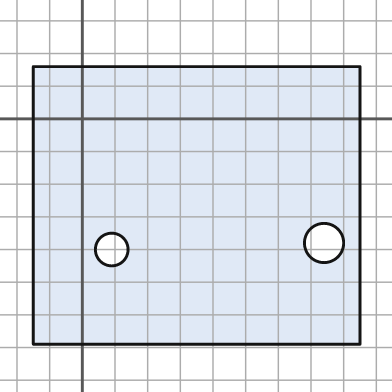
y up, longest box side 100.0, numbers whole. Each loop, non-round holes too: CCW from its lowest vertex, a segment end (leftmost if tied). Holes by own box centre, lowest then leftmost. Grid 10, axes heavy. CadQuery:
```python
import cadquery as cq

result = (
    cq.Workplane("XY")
    .moveTo(-15.0, -69.0)
    .lineTo(85.0, -69.0)
    .lineTo(85.0, 16.0)
    .lineTo(-15.0, 16.0)
    .close()
    .moveTo(9.0, -40.0)
    .circle(5.0)
    .moveTo(74.0, -38.0)
    .circle(6.0)
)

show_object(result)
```